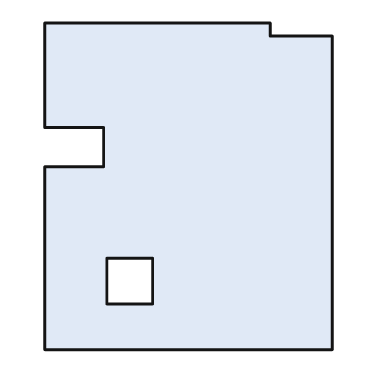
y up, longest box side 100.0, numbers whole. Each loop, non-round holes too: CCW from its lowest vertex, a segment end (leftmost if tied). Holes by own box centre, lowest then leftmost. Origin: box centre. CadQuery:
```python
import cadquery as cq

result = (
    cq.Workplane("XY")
    .moveTo(-44.0, -50.0)
    .lineTo(44.0, -50.0)
    .lineTo(44.0, 46.0)
    .lineTo(25.0, 46.0)
    .lineTo(25.0, 50.0)
    .lineTo(-44.0, 50.0)
    .lineTo(-44.0, 18.0)
    .lineTo(-26.0, 18.0)
    .lineTo(-26.0, 6.0)
    .lineTo(-44.0, 6.0)
    .close()
    .moveTo(-25.0, -36.0)
    .lineTo(-11.0, -36.0)
    .lineTo(-11.0, -22.0)
    .lineTo(-25.0, -22.0)
    .close()
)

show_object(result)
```